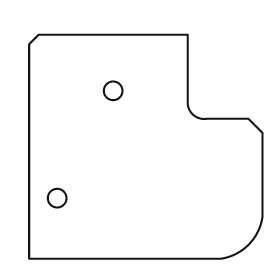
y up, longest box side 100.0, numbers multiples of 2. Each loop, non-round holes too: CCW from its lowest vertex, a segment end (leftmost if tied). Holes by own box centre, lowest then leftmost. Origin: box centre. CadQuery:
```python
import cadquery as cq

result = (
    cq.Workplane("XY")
    .moveTo(-50.0, -48.0)
    .lineTo(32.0, -48.0)
    .threePointArc((44.0, -42.0), (50.0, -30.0))
    .lineTo(50.0, 6.0)
    .lineTo(44.0, 12.0)
    .lineTo(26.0, 12.0)
    .threePointArc((20.0, 14.0), (18.0, 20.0))
    .lineTo(18.0, 48.0)
    .lineTo(-46.0, 48.0)
    .lineTo(-50.0, 44.0)
    .close()
    .moveTo(-38.0, -22.0)
    .circle(4.0)
    .moveTo(-14.0, 24.0)
    .circle(4.0)
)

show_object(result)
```